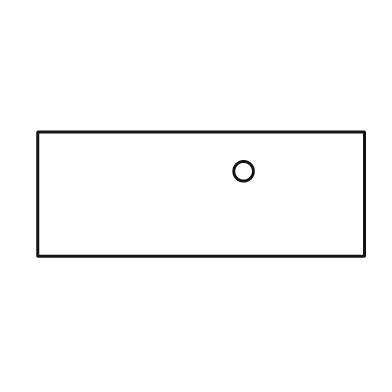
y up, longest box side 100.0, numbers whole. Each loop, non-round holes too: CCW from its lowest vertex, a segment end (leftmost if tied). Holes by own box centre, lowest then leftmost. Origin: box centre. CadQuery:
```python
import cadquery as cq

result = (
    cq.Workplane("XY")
    .moveTo(-50.0, -19.0)
    .lineTo(50.0, -19.0)
    .lineTo(50.0, 19.0)
    .lineTo(-50.0, 19.0)
    .close()
    .moveTo(13.0, 7.0)
    .circle(3.0)
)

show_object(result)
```